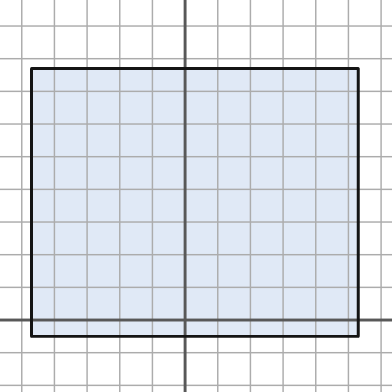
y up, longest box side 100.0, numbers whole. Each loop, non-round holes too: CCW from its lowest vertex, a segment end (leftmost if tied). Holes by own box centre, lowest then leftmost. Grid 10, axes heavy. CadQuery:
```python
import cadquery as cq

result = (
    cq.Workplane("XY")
    .moveTo(-47.0, -5.0)
    .lineTo(53.0, -5.0)
    .lineTo(53.0, 77.0)
    .lineTo(-47.0, 77.0)
    .close()
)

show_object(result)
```